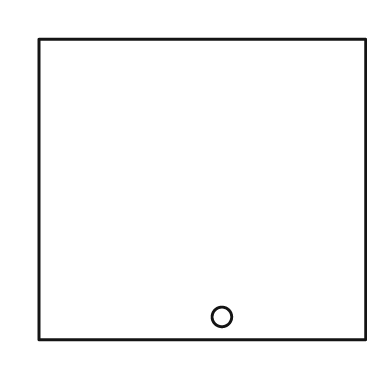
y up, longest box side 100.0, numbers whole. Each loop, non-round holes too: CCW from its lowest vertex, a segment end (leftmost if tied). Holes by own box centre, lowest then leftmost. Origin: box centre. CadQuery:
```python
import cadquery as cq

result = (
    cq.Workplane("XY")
    .moveTo(-50.0, -46.0)
    .lineTo(50.0, -46.0)
    .lineTo(50.0, 46.0)
    .lineTo(-50.0, 46.0)
    .close()
    .moveTo(6.0, -39.0)
    .circle(3.0)
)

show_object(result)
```